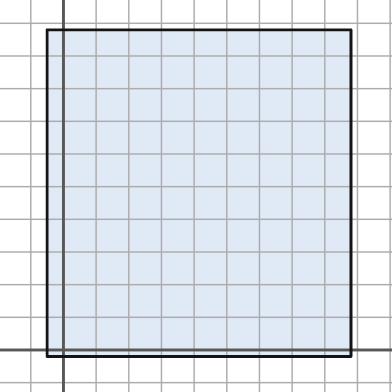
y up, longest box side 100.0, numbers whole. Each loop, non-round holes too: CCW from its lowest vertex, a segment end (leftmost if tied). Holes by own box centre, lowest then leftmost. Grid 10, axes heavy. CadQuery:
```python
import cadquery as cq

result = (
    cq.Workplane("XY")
    .moveTo(-5.0, -2.0)
    .lineTo(88.0, -2.0)
    .lineTo(88.0, 98.0)
    .lineTo(-5.0, 98.0)
    .close()
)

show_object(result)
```